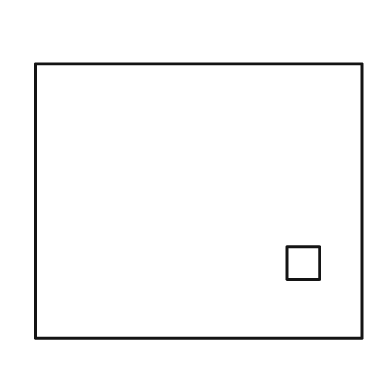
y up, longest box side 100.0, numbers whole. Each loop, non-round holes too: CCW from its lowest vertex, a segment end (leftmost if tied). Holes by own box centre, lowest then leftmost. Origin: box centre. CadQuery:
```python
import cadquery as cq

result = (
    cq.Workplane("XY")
    .moveTo(-50.0, -42.0)
    .lineTo(50.0, -42.0)
    .lineTo(50.0, 42.0)
    .lineTo(-50.0, 42.0)
    .close()
    .moveTo(27.0, -24.0)
    .lineTo(37.0, -24.0)
    .lineTo(37.0, -14.0)
    .lineTo(27.0, -14.0)
    .close()
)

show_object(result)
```